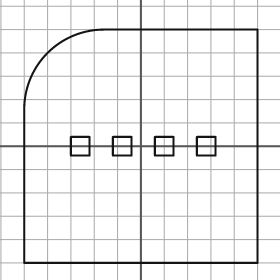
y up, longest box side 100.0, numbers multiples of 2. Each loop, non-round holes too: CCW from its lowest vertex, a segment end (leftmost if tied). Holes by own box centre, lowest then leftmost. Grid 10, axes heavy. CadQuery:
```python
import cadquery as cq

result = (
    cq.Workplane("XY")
    .moveTo(-50.0, -50.0)
    .lineTo(50.0, -50.0)
    .lineTo(50.0, 50.0)
    .lineTo(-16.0, 50.0)
    .threePointArc((-40.0, 40.0), (-50.0, 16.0))
    .close()
    .moveTo(-30.0, -4.0)
    .lineTo(-22.0, -4.0)
    .lineTo(-22.0, 4.0)
    .lineTo(-30.0, 4.0)
    .close()
    .moveTo(-12.0, -4.0)
    .lineTo(-4.0, -4.0)
    .lineTo(-4.0, 4.0)
    .lineTo(-12.0, 4.0)
    .close()
    .moveTo(6.0, -4.0)
    .lineTo(14.0, -4.0)
    .lineTo(14.0, 4.0)
    .lineTo(6.0, 4.0)
    .close()
    .moveTo(24.0, -4.0)
    .lineTo(32.0, -4.0)
    .lineTo(32.0, 4.0)
    .lineTo(24.0, 4.0)
    .close()
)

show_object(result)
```